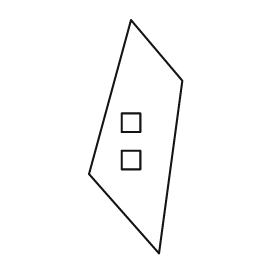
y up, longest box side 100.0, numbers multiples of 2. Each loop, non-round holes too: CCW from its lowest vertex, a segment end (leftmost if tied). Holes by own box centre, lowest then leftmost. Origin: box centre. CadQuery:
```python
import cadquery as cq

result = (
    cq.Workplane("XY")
    .moveTo(10.0, -50.0)
    .lineTo(20.0, 24.0)
    .lineTo(-2.0, 50.0)
    .lineTo(-20.0, -16.0)
    .close()
    .moveTo(-6.0, -14.0)
    .lineTo(2.0, -14.0)
    .lineTo(2.0, -6.0)
    .lineTo(-6.0, -6.0)
    .close()
    .moveTo(-6.0, 2.0)
    .lineTo(2.0, 2.0)
    .lineTo(2.0, 10.0)
    .lineTo(-6.0, 10.0)
    .close()
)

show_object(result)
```